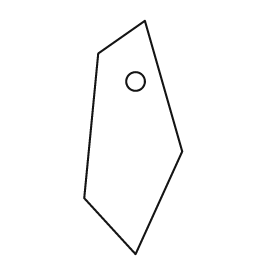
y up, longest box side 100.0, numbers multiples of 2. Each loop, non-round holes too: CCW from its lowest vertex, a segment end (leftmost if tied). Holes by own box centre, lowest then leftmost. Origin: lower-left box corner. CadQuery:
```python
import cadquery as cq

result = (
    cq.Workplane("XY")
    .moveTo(22.0, 0.0)
    .lineTo(42.0, 44.0)
    .lineTo(26.0, 100.0)
    .lineTo(6.0, 86.0)
    .lineTo(0.0, 24.0)
    .close()
    .moveTo(22.0, 74.0)
    .circle(4.0)
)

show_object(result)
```